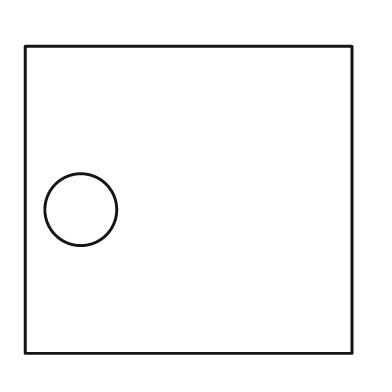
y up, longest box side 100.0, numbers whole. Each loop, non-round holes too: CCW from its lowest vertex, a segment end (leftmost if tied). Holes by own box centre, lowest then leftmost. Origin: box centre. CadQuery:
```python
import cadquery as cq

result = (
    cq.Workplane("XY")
    .moveTo(-50.0, -47.0)
    .lineTo(50.0, -47.0)
    .lineTo(50.0, 47.0)
    .lineTo(-50.0, 47.0)
    .close()
    .moveTo(-33.0, -3.0)
    .circle(11.0)
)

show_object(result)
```